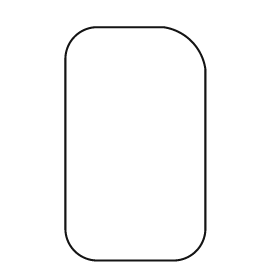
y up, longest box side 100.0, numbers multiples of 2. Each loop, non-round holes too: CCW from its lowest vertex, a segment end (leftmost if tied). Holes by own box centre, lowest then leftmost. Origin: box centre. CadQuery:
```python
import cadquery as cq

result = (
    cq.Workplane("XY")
    .moveTo(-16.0, -50.0)
    .lineTo(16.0, -50.0)
    .threePointArc((26.0, -46.0), (30.0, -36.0))
    .lineTo(30.0, 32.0)
    .threePointArc((24.0, 44.0), (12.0, 50.0))
    .lineTo(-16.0, 50.0)
    .threePointArc((-26.0, 46.0), (-30.0, 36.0))
    .lineTo(-30.0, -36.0)
    .threePointArc((-26.0, -46.0), (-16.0, -50.0))
    .close()
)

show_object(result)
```